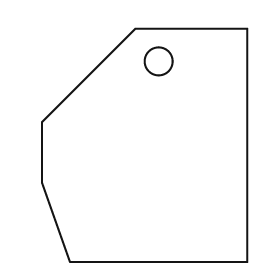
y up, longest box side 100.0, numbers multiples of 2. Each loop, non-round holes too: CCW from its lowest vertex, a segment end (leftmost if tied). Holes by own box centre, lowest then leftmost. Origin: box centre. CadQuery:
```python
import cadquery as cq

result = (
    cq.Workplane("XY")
    .moveTo(-32.0, -50.0)
    .lineTo(44.0, -50.0)
    .lineTo(44.0, 50.0)
    .lineTo(-4.0, 50.0)
    .lineTo(-44.0, 10.0)
    .lineTo(-44.0, -16.0)
    .close()
    .moveTo(6.0, 36.0)
    .circle(6.0)
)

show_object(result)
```